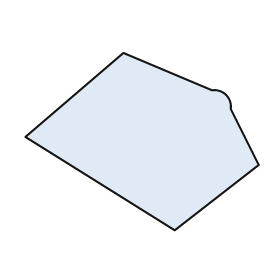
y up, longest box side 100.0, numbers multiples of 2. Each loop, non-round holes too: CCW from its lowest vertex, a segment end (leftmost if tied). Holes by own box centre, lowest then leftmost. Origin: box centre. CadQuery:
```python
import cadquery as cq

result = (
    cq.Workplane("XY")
    .moveTo(14.0, -38.0)
    .lineTo(50.0, -10.0)
    .lineTo(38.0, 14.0)
    .threePointArc((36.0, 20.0), (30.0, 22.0))
    .lineTo(-8.0, 38.0)
    .lineTo(-50.0, 2.0)
    .close()
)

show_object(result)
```